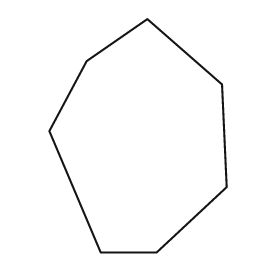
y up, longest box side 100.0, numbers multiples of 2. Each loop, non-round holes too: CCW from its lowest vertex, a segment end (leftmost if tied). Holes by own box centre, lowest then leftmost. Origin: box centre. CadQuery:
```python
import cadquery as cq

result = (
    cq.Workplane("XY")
    .moveTo(-16.0, -50.0)
    .lineTo(8.0, -50.0)
    .lineTo(38.0, -22.0)
    .lineTo(36.0, 22.0)
    .lineTo(4.0, 50.0)
    .lineTo(-22.0, 32.0)
    .lineTo(-38.0, 2.0)
    .close()
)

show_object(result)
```